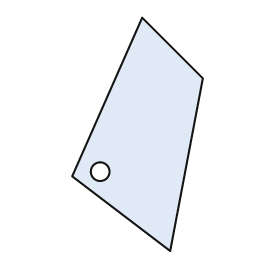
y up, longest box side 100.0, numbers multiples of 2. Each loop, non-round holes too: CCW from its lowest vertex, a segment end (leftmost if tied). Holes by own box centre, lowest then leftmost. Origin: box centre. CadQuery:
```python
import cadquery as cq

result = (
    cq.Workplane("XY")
    .moveTo(14.0, -50.0)
    .lineTo(28.0, 24.0)
    .lineTo(2.0, 50.0)
    .lineTo(-28.0, -18.0)
    .close()
    .moveTo(-16.0, -16.0)
    .circle(4.0)
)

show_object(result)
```